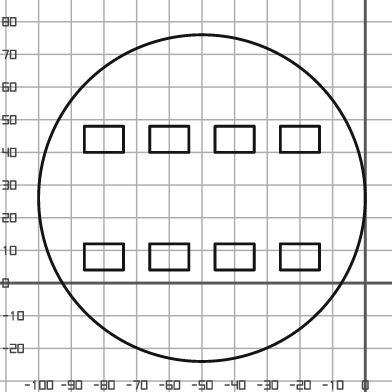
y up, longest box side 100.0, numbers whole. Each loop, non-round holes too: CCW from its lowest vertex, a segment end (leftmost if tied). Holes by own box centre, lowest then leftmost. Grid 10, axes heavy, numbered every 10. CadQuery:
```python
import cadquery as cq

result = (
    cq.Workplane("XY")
    .moveTo(-50.0, 26.0)
    .circle(50.0)
    .moveTo(-86.0, 4.0)
    .lineTo(-74.0, 4.0)
    .lineTo(-74.0, 12.0)
    .lineTo(-86.0, 12.0)
    .close()
    .moveTo(-66.0, 4.0)
    .lineTo(-54.0, 4.0)
    .lineTo(-54.0, 12.0)
    .lineTo(-66.0, 12.0)
    .close()
    .moveTo(-46.0, 4.0)
    .lineTo(-34.0, 4.0)
    .lineTo(-34.0, 12.0)
    .lineTo(-46.0, 12.0)
    .close()
    .moveTo(-26.0, 4.0)
    .lineTo(-14.0, 4.0)
    .lineTo(-14.0, 12.0)
    .lineTo(-26.0, 12.0)
    .close()
    .moveTo(-86.0, 40.0)
    .lineTo(-74.0, 40.0)
    .lineTo(-74.0, 48.0)
    .lineTo(-86.0, 48.0)
    .close()
    .moveTo(-66.0, 40.0)
    .lineTo(-54.0, 40.0)
    .lineTo(-54.0, 48.0)
    .lineTo(-66.0, 48.0)
    .close()
    .moveTo(-46.0, 40.0)
    .lineTo(-34.0, 40.0)
    .lineTo(-34.0, 48.0)
    .lineTo(-46.0, 48.0)
    .close()
    .moveTo(-26.0, 40.0)
    .lineTo(-14.0, 40.0)
    .lineTo(-14.0, 48.0)
    .lineTo(-26.0, 48.0)
    .close()
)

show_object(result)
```